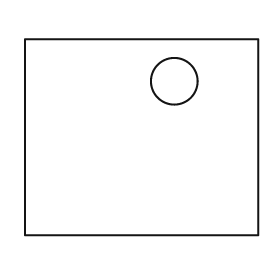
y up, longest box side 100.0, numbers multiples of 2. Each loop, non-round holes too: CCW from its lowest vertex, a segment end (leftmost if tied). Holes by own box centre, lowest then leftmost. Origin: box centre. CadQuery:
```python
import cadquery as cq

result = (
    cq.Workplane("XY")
    .moveTo(-50.0, -42.0)
    .lineTo(50.0, -42.0)
    .lineTo(50.0, 42.0)
    .lineTo(-50.0, 42.0)
    .close()
    .moveTo(14.0, 24.0)
    .circle(10.0)
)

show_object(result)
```